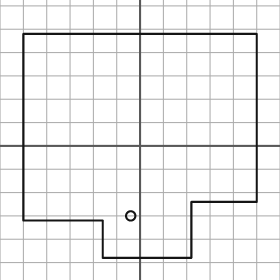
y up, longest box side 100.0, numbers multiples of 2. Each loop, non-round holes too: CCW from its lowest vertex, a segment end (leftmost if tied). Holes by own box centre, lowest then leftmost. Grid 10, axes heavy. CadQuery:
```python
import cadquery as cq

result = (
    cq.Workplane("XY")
    .moveTo(-16.0, -48.0)
    .lineTo(22.0, -48.0)
    .lineTo(22.0, -24.0)
    .lineTo(50.0, -24.0)
    .lineTo(50.0, 48.0)
    .lineTo(-50.0, 48.0)
    .lineTo(-50.0, -32.0)
    .lineTo(-16.0, -32.0)
    .close()
    .moveTo(-4.0, -30.0)
    .circle(2.0)
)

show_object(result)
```